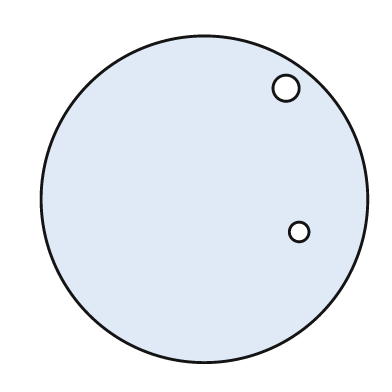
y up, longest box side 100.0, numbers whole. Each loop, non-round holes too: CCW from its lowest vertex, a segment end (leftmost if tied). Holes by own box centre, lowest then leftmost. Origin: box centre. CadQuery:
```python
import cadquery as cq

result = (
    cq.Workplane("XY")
    .moveTo(0.0, 0.0)
    .circle(50.0)
    .moveTo(29.0, -10.0)
    .circle(3.0)
    .moveTo(25.0, 34.0)
    .circle(4.0)
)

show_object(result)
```